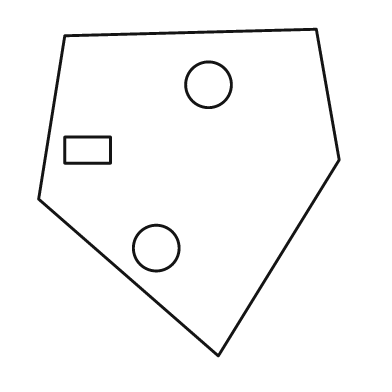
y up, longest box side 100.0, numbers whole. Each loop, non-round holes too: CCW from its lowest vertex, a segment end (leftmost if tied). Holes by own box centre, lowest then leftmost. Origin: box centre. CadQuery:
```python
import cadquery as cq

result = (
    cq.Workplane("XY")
    .moveTo(9.0, -50.0)
    .lineTo(46.0, 10.0)
    .lineTo(39.0, 50.0)
    .lineTo(-38.0, 48.0)
    .lineTo(-46.0, -2.0)
    .close()
    .moveTo(-10.0, -17.0)
    .circle(7.0)
    .moveTo(-38.0, 9.0)
    .lineTo(-24.0, 9.0)
    .lineTo(-24.0, 17.0)
    .lineTo(-38.0, 17.0)
    .close()
    .moveTo(6.0, 33.0)
    .circle(7.0)
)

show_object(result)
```